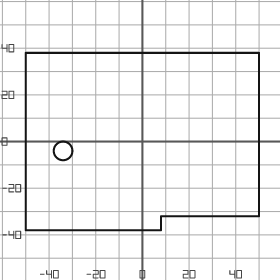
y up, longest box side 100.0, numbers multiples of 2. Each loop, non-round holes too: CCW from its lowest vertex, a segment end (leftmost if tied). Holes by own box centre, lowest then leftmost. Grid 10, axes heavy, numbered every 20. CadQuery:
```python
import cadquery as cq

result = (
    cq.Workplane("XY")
    .moveTo(-50.0, -38.0)
    .lineTo(8.0, -38.0)
    .lineTo(8.0, -32.0)
    .lineTo(50.0, -32.0)
    .lineTo(50.0, 38.0)
    .lineTo(-50.0, 38.0)
    .close()
    .moveTo(-34.0, -4.0)
    .circle(4.0)
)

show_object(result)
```